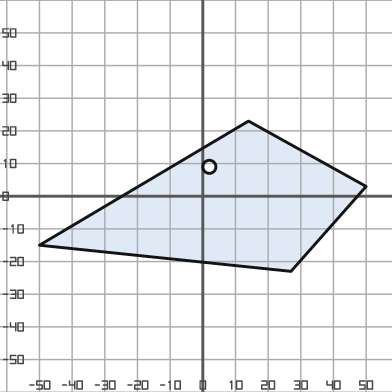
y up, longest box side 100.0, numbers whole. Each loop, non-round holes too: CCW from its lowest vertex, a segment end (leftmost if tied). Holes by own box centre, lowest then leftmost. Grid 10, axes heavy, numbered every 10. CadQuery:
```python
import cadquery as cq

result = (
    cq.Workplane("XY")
    .moveTo(27.0, -23.0)
    .lineTo(50.0, 3.0)
    .lineTo(14.0, 23.0)
    .lineTo(-50.0, -15.0)
    .close()
    .moveTo(2.0, 9.0)
    .circle(2.0)
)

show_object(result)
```